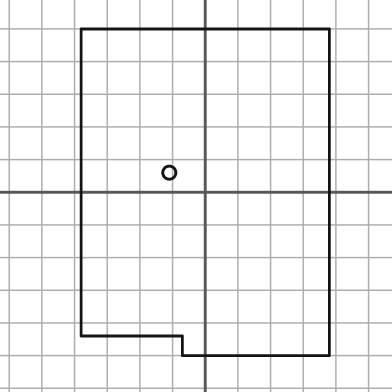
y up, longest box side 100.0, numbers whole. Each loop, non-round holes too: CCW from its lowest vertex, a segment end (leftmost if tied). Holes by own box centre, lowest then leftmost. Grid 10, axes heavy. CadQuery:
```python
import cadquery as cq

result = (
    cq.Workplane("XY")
    .moveTo(-7.0, -50.0)
    .lineTo(38.0, -50.0)
    .lineTo(38.0, 50.0)
    .lineTo(-38.0, 50.0)
    .lineTo(-38.0, -44.0)
    .lineTo(-7.0, -44.0)
    .close()
    .moveTo(-11.0, 6.0)
    .circle(2.0)
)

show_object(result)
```